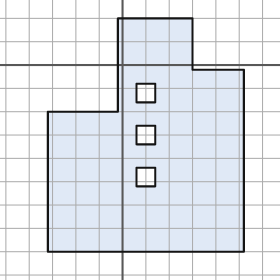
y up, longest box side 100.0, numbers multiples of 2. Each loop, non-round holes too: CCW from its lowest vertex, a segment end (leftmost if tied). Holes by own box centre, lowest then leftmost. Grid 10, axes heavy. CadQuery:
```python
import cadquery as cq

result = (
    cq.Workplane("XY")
    .moveTo(-32.0, -80.0)
    .lineTo(52.0, -80.0)
    .lineTo(52.0, -2.0)
    .lineTo(30.0, -2.0)
    .lineTo(30.0, 20.0)
    .lineTo(-2.0, 20.0)
    .lineTo(-2.0, -20.0)
    .lineTo(-32.0, -20.0)
    .close()
    .moveTo(6.0, -52.0)
    .lineTo(14.0, -52.0)
    .lineTo(14.0, -44.0)
    .lineTo(6.0, -44.0)
    .close()
    .moveTo(6.0, -34.0)
    .lineTo(14.0, -34.0)
    .lineTo(14.0, -26.0)
    .lineTo(6.0, -26.0)
    .close()
    .moveTo(6.0, -16.0)
    .lineTo(14.0, -16.0)
    .lineTo(14.0, -8.0)
    .lineTo(6.0, -8.0)
    .close()
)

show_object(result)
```